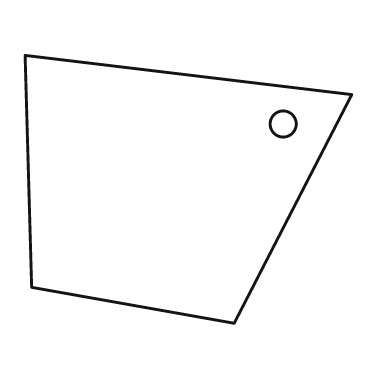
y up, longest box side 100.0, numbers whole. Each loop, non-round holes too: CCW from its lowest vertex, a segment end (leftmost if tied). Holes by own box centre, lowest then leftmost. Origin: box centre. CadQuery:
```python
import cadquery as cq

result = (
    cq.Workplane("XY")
    .moveTo(14.0, -41.0)
    .lineTo(50.0, 29.0)
    .lineTo(-50.0, 41.0)
    .lineTo(-48.0, -30.0)
    .close()
    .moveTo(29.0, 20.0)
    .circle(4.0)
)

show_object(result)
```